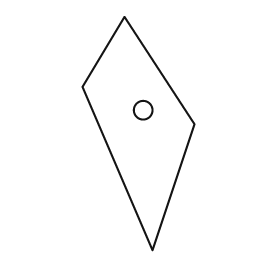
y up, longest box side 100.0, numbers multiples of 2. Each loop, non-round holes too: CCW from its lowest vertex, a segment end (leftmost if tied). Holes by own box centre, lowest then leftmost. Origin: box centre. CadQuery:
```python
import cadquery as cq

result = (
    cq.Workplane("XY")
    .moveTo(6.0, -50.0)
    .lineTo(24.0, 4.0)
    .lineTo(-6.0, 50.0)
    .lineTo(-24.0, 20.0)
    .close()
    .moveTo(2.0, 10.0)
    .circle(4.0)
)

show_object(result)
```